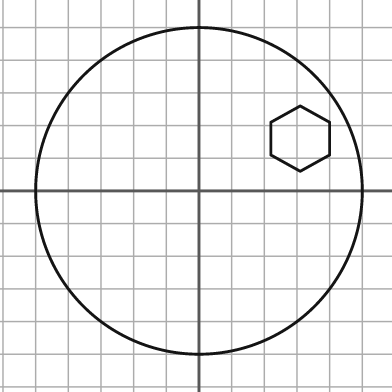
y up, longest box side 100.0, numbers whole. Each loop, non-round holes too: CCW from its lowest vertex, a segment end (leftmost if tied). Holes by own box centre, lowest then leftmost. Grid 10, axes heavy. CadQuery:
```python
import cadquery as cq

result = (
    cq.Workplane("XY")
    .moveTo(0.0, 0.0)
    .circle(50.0)
    .moveTo(31.0, 6.0)
    .lineTo(40.0, 11.0)
    .lineTo(40.0, 21.0)
    .lineTo(31.0, 26.0)
    .lineTo(22.0, 21.0)
    .lineTo(22.0, 11.0)
    .close()
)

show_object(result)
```